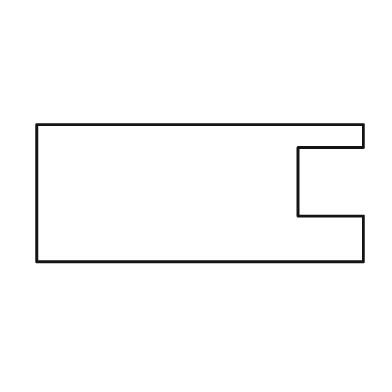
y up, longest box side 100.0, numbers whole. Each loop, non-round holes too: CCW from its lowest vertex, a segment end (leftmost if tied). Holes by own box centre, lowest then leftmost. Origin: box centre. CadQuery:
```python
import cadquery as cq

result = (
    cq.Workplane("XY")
    .moveTo(-50.0, -21.0)
    .lineTo(50.0, -21.0)
    .lineTo(50.0, -7.0)
    .lineTo(30.0, -7.0)
    .lineTo(30.0, 14.0)
    .lineTo(50.0, 14.0)
    .lineTo(50.0, 21.0)
    .lineTo(-50.0, 21.0)
    .close()
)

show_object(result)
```